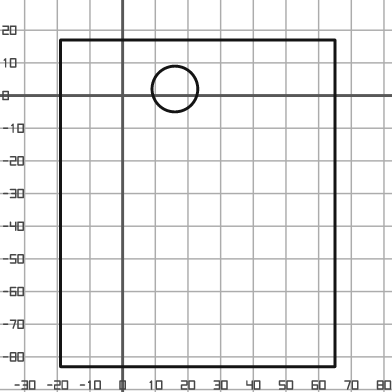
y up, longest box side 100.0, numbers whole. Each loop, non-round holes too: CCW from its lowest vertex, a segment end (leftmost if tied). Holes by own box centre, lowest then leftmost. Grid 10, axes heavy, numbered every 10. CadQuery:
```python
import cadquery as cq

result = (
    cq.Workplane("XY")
    .moveTo(-19.0, -83.0)
    .lineTo(65.0, -83.0)
    .lineTo(65.0, 17.0)
    .lineTo(-19.0, 17.0)
    .close()
    .moveTo(16.0, 2.0)
    .circle(7.0)
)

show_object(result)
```